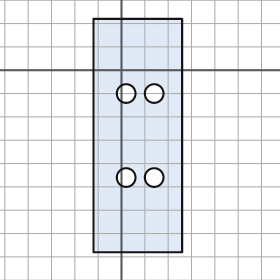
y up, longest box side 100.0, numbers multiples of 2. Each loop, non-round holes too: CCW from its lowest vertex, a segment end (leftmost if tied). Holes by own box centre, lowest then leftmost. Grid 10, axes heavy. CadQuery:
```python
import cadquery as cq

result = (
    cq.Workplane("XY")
    .moveTo(-12.0, -78.0)
    .lineTo(26.0, -78.0)
    .lineTo(26.0, 22.0)
    .lineTo(-12.0, 22.0)
    .close()
    .moveTo(2.0, -46.0)
    .circle(4.0)
    .moveTo(14.0, -46.0)
    .circle(4.0)
    .moveTo(2.0, -10.0)
    .circle(4.0)
    .moveTo(14.0, -10.0)
    .circle(4.0)
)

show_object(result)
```